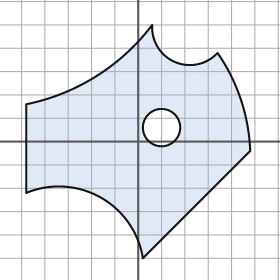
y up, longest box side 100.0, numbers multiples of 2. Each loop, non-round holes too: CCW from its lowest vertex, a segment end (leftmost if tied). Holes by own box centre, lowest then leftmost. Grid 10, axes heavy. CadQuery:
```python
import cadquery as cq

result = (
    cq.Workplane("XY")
    .moveTo(2.0, -50.0)
    .lineTo(48.0, -4.0)
    .threePointArc((44.0, 18.0), (34.0, 38.0))
    .threePointArc((16.0, 34.0), (6.0, 50.0))
    .threePointArc((-18.0, 28.0), (-48.0, 16.0))
    .lineTo(-48.0, -22.0)
    .threePointArc((-16.0, -24.0), (2.0, -50.0))
    .close()
    .moveTo(10.0, 6.0)
    .circle(8.0)
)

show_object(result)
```